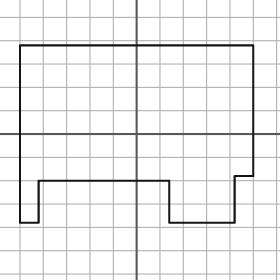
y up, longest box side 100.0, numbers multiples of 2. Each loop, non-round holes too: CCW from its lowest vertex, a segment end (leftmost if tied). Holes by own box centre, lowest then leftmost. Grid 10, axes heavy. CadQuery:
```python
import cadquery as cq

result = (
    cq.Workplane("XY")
    .moveTo(-50.0, -38.0)
    .lineTo(-42.0, -38.0)
    .lineTo(-42.0, -20.0)
    .lineTo(14.0, -20.0)
    .lineTo(14.0, -38.0)
    .lineTo(42.0, -38.0)
    .lineTo(42.0, -18.0)
    .lineTo(50.0, -18.0)
    .lineTo(50.0, 38.0)
    .lineTo(-50.0, 38.0)
    .close()
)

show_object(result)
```